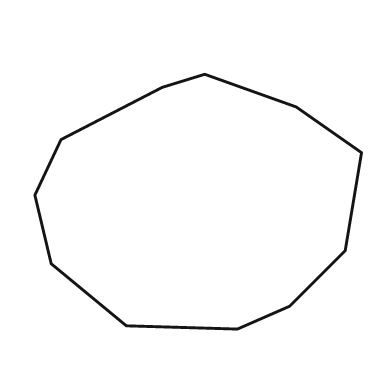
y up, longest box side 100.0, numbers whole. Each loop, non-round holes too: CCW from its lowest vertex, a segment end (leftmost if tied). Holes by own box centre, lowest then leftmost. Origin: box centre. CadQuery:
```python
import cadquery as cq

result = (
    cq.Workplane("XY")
    .moveTo(12.0, -39.0)
    .lineTo(28.0, -32.0)
    .lineTo(45.0, -15.0)
    .lineTo(50.0, 15.0)
    .lineTo(30.0, 29.0)
    .lineTo(2.0, 39.0)
    .lineTo(-11.0, 35.0)
    .lineTo(-42.0, 19.0)
    .lineTo(-50.0, 2.0)
    .lineTo(-45.0, -19.0)
    .lineTo(-22.0, -38.0)
    .close()
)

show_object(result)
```